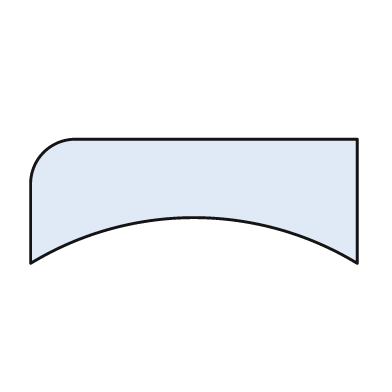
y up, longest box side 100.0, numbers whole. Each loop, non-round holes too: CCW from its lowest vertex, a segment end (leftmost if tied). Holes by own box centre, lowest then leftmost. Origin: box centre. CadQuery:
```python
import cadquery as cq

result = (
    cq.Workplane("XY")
    .moveTo(-50.0, -19.0)
    .threePointArc((0.0, -5.0), (50.0, -19.0))
    .lineTo(50.0, 19.0)
    .lineTo(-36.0, 19.0)
    .threePointArc((-46.0, 15.0), (-50.0, 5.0))
    .close()
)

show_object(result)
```